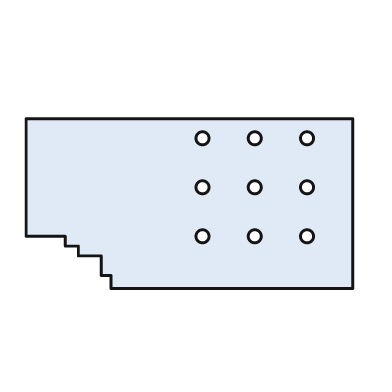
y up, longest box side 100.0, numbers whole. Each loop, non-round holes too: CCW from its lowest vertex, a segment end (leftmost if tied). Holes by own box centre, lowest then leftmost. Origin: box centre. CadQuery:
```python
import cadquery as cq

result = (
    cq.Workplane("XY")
    .moveTo(-24.0, -26.0)
    .lineTo(50.0, -26.0)
    .lineTo(50.0, 26.0)
    .lineTo(-50.0, 26.0)
    .lineTo(-50.0, -10.0)
    .lineTo(-38.0, -10.0)
    .lineTo(-38.0, -13.0)
    .lineTo(-34.0, -13.0)
    .lineTo(-34.0, -16.0)
    .lineTo(-27.0, -16.0)
    .lineTo(-27.0, -22.0)
    .lineTo(-24.0, -22.0)
    .close()
    .moveTo(4.0, -10.0)
    .circle(2.0)
    .moveTo(20.0, -10.0)
    .circle(2.0)
    .moveTo(36.0, -10.0)
    .circle(2.0)
    .moveTo(4.0, 5.0)
    .circle(2.0)
    .moveTo(20.0, 5.0)
    .circle(2.0)
    .moveTo(36.0, 5.0)
    .circle(2.0)
    .moveTo(4.0, 20.0)
    .circle(2.0)
    .moveTo(20.0, 20.0)
    .circle(2.0)
    .moveTo(36.0, 20.0)
    .circle(2.0)
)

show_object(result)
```